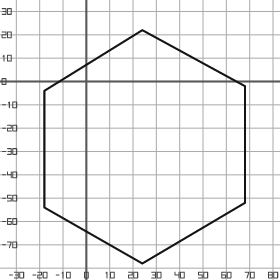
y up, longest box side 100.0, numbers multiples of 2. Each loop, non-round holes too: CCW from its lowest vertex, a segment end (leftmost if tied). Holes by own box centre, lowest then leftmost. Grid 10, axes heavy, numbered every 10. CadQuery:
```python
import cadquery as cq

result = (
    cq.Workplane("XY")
    .moveTo(24.0, -78.0)
    .lineTo(68.0, -52.0)
    .lineTo(68.0, -2.0)
    .lineTo(24.0, 22.0)
    .lineTo(-18.0, -4.0)
    .lineTo(-18.0, -54.0)
    .close()
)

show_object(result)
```